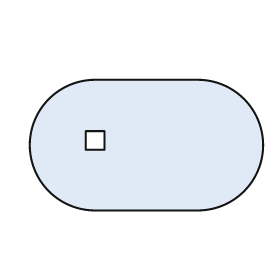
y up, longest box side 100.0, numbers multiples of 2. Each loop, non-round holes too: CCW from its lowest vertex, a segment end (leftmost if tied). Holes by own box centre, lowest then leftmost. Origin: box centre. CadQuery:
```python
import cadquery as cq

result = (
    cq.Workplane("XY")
    .moveTo(-22.0, -28.0)
    .lineTo(22.0, -28.0)
    .threePointArc((50.0, 0.0), (22.0, 28.0))
    .lineTo(-22.0, 28.0)
    .threePointArc((-50.0, 0.0), (-22.0, -28.0))
    .close()
    .moveTo(-26.0, -2.0)
    .lineTo(-18.0, -2.0)
    .lineTo(-18.0, 6.0)
    .lineTo(-26.0, 6.0)
    .close()
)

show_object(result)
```